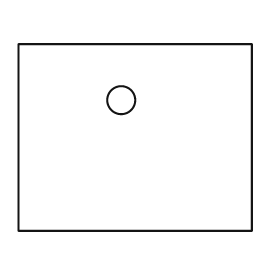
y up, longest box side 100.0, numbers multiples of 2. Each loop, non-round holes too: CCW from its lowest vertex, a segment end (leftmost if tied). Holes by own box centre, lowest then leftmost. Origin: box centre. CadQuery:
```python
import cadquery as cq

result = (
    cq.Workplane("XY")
    .moveTo(-50.0, -40.0)
    .lineTo(50.0, -40.0)
    .lineTo(50.0, 40.0)
    .lineTo(-50.0, 40.0)
    .close()
    .moveTo(-6.0, 16.0)
    .circle(6.0)
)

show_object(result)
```